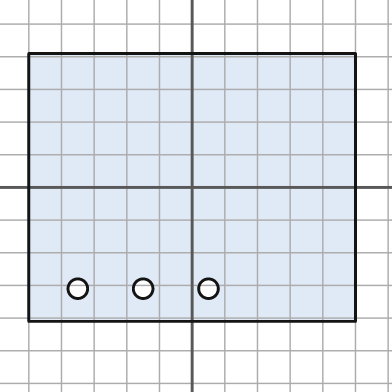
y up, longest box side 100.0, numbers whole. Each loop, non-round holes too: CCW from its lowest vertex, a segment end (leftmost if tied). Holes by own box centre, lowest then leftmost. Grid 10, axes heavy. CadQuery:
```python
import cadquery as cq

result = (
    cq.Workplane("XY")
    .moveTo(-50.0, -41.0)
    .lineTo(50.0, -41.0)
    .lineTo(50.0, 41.0)
    .lineTo(-50.0, 41.0)
    .close()
    .moveTo(-35.0, -31.0)
    .circle(3.0)
    .moveTo(-15.0, -31.0)
    .circle(3.0)
    .moveTo(5.0, -31.0)
    .circle(3.0)
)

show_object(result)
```